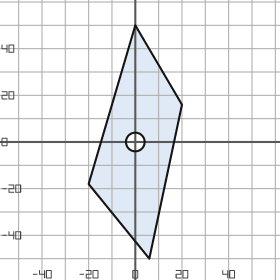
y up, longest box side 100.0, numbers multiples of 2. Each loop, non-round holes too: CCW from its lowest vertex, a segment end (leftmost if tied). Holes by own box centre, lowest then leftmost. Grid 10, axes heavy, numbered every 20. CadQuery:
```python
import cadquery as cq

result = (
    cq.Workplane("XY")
    .moveTo(6.0, -50.0)
    .lineTo(20.0, 16.0)
    .lineTo(0.0, 50.0)
    .lineTo(-20.0, -18.0)
    .close()
    .moveTo(0.0, 0.0)
    .circle(4.0)
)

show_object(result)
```